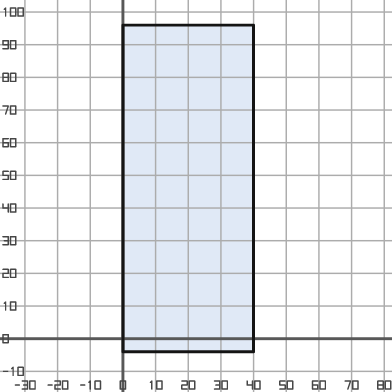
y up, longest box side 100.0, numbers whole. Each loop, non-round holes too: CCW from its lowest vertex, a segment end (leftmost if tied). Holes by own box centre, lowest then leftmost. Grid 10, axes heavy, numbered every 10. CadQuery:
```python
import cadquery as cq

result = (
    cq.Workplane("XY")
    .moveTo(0.0, -4.0)
    .lineTo(40.0, -4.0)
    .lineTo(40.0, 96.0)
    .lineTo(0.0, 96.0)
    .close()
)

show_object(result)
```